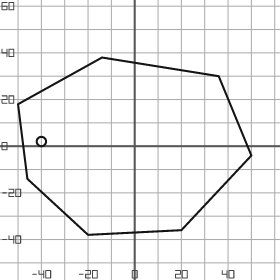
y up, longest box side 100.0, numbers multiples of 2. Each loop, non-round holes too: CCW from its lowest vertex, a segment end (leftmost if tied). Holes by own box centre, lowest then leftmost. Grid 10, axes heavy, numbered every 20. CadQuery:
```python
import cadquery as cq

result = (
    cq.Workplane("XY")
    .moveTo(-20.0, -38.0)
    .lineTo(20.0, -36.0)
    .lineTo(50.0, -4.0)
    .lineTo(36.0, 30.0)
    .lineTo(-14.0, 38.0)
    .lineTo(-50.0, 18.0)
    .lineTo(-46.0, -14.0)
    .close()
    .moveTo(-40.0, 2.0)
    .circle(2.0)
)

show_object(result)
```